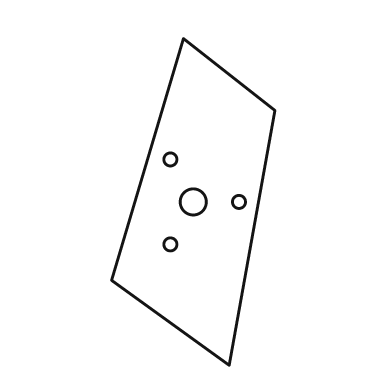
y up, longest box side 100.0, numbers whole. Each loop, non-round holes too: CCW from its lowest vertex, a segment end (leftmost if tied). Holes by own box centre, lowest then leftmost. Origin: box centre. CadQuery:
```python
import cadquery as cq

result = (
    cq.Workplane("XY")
    .moveTo(11.0, -50.0)
    .lineTo(25.0, 28.0)
    .lineTo(-3.0, 50.0)
    .lineTo(-25.0, -24.0)
    .close()
    .moveTo(-7.0, -13.0)
    .circle(2.0)
    .moveTo(0.0, 0.0)
    .circle(4.0)
    .moveTo(14.0, 0.0)
    .circle(2.0)
    .moveTo(-7.0, 13.0)
    .circle(2.0)
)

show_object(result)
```